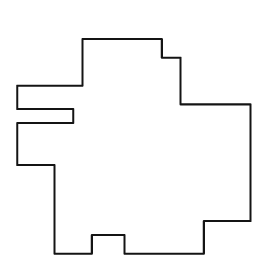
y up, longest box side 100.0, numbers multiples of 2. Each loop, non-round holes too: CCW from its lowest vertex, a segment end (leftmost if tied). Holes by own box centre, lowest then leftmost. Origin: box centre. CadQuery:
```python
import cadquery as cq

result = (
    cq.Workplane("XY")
    .moveTo(-34.0, -46.0)
    .lineTo(-18.0, -46.0)
    .lineTo(-18.0, -38.0)
    .lineTo(-4.0, -38.0)
    .lineTo(-4.0, -46.0)
    .lineTo(30.0, -46.0)
    .lineTo(30.0, -32.0)
    .lineTo(50.0, -32.0)
    .lineTo(50.0, 18.0)
    .lineTo(20.0, 18.0)
    .lineTo(20.0, 38.0)
    .lineTo(12.0, 38.0)
    .lineTo(12.0, 46.0)
    .lineTo(-22.0, 46.0)
    .lineTo(-22.0, 26.0)
    .lineTo(-50.0, 26.0)
    .lineTo(-50.0, 16.0)
    .lineTo(-26.0, 16.0)
    .lineTo(-26.0, 10.0)
    .lineTo(-50.0, 10.0)
    .lineTo(-50.0, -8.0)
    .lineTo(-34.0, -8.0)
    .close()
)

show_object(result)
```